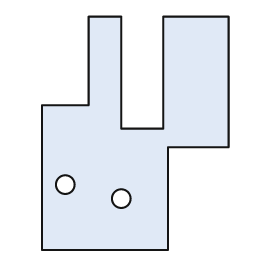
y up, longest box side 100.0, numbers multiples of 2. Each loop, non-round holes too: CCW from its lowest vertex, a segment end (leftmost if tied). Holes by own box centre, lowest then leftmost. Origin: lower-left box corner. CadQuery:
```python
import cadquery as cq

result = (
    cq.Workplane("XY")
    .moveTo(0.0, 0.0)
    .lineTo(54.0, 0.0)
    .lineTo(54.0, 44.0)
    .lineTo(80.0, 44.0)
    .lineTo(80.0, 100.0)
    .lineTo(52.0, 100.0)
    .lineTo(52.0, 52.0)
    .lineTo(34.0, 52.0)
    .lineTo(34.0, 100.0)
    .lineTo(20.0, 100.0)
    .lineTo(20.0, 62.0)
    .lineTo(0.0, 62.0)
    .close()
    .moveTo(34.0, 22.0)
    .circle(4.0)
    .moveTo(10.0, 28.0)
    .circle(4.0)
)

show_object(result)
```